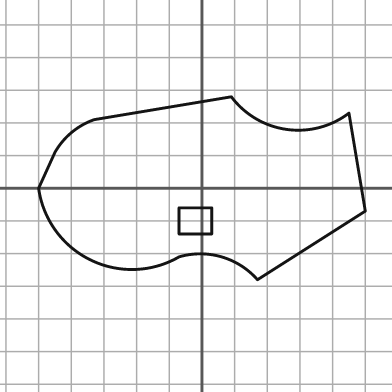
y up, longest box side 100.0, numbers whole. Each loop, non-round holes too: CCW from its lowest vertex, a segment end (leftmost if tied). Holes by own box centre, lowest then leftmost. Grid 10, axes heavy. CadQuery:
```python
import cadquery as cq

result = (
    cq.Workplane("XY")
    .moveTo(17.0, -28.0)
    .lineTo(50.0, -7.0)
    .lineTo(45.0, 23.0)
    .threePointArc((26.0, 18.0), (9.0, 28.0))
    .lineTo(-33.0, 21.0)
    .threePointArc((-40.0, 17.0), (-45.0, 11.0))
    .lineTo(-50.0, 0.0)
    .threePointArc((-34.0, -22.0), (-7.0, -21.0))
    .threePointArc((6.0, -21.0), (17.0, -28.0))
    .close()
    .moveTo(-7.0, -14.0)
    .lineTo(3.0, -14.0)
    .lineTo(3.0, -6.0)
    .lineTo(-7.0, -6.0)
    .close()
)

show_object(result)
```